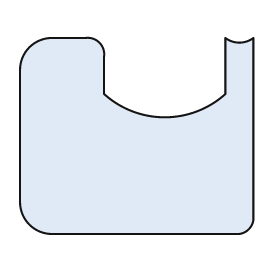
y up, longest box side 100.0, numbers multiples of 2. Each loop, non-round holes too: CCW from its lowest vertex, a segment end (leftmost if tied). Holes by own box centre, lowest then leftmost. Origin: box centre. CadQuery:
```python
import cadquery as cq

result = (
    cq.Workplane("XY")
    .moveTo(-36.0, -42.0)
    .lineTo(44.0, -42.0)
    .threePointArc((48.0, -40.0), (50.0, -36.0))
    .lineTo(50.0, 42.0)
    .threePointArc((44.0, 40.0), (38.0, 42.0))
    .lineTo(38.0, 18.0)
    .threePointArc((12.0, 8.0), (-14.0, 18.0))
    .lineTo(-14.0, 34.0)
    .threePointArc((-16.0, 40.0), (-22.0, 42.0))
    .lineTo(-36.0, 42.0)
    .threePointArc((-46.0, 38.0), (-50.0, 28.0))
    .lineTo(-50.0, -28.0)
    .threePointArc((-46.0, -38.0), (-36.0, -42.0))
    .close()
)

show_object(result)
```